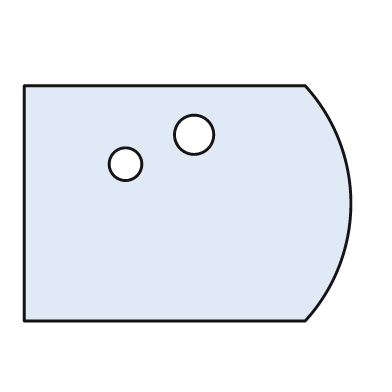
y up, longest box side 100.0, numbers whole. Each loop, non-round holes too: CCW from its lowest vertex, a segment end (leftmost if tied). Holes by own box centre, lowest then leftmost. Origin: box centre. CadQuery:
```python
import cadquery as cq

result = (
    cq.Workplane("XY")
    .moveTo(-50.0, -36.0)
    .lineTo(36.0, -36.0)
    .threePointArc((50.0, 0.0), (36.0, 36.0))
    .lineTo(-50.0, 36.0)
    .close()
    .moveTo(-19.0, 12.0)
    .circle(5.0)
    .moveTo(2.0, 21.0)
    .circle(6.0)
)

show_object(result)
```